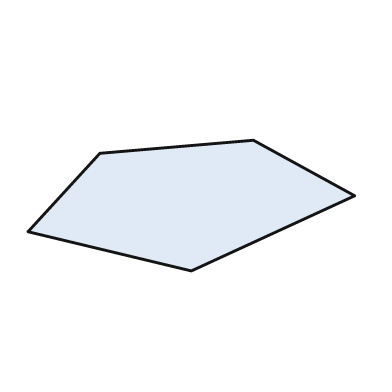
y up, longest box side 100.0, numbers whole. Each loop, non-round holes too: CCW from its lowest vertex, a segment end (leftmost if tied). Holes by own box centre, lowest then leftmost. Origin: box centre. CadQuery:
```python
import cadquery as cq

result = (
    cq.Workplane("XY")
    .moveTo(0.0, -20.0)
    .lineTo(50.0, 3.0)
    .lineTo(19.0, 20.0)
    .lineTo(-28.0, 16.0)
    .lineTo(-50.0, -8.0)
    .close()
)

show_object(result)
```